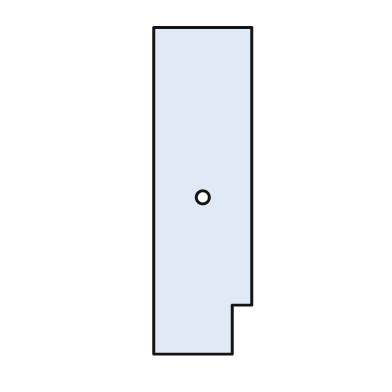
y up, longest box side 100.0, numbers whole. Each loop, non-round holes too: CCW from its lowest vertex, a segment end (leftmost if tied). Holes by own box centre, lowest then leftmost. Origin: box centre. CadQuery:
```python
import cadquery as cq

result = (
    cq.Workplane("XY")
    .moveTo(-15.0, -50.0)
    .lineTo(9.0, -50.0)
    .lineTo(9.0, -35.0)
    .lineTo(15.0, -35.0)
    .lineTo(15.0, 50.0)
    .lineTo(-15.0, 50.0)
    .close()
    .moveTo(0.0, -2.0)
    .circle(2.0)
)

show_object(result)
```